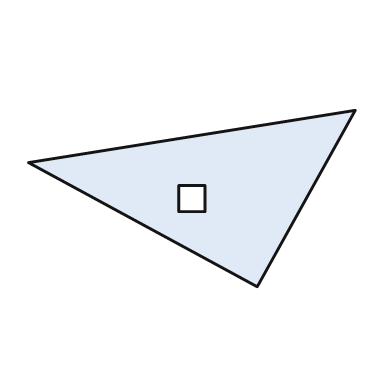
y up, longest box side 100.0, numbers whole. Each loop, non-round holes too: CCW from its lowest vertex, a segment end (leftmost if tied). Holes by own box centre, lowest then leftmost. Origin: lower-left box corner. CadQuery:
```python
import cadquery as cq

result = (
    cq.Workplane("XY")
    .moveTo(70.0, 0.0)
    .lineTo(100.0, 54.0)
    .lineTo(0.0, 38.0)
    .close()
    .moveTo(46.0, 23.0)
    .lineTo(54.0, 23.0)
    .lineTo(54.0, 31.0)
    .lineTo(46.0, 31.0)
    .close()
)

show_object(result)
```